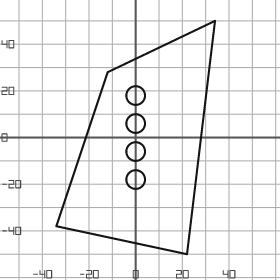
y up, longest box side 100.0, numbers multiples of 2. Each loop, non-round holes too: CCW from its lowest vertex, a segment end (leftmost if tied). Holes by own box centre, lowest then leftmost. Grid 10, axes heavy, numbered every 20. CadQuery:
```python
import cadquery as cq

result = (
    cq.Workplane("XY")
    .moveTo(22.0, -50.0)
    .lineTo(34.0, 50.0)
    .lineTo(-12.0, 28.0)
    .lineTo(-34.0, -38.0)
    .close()
    .moveTo(0.0, -18.0)
    .circle(4.0)
    .moveTo(0.0, -6.0)
    .circle(4.0)
    .moveTo(0.0, 6.0)
    .circle(4.0)
    .moveTo(0.0, 18.0)
    .circle(4.0)
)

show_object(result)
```